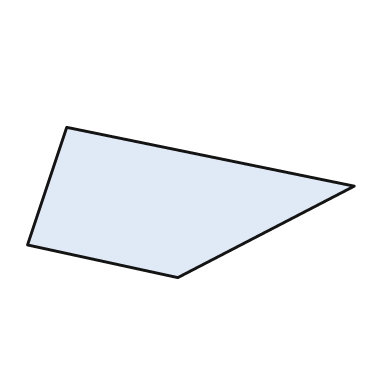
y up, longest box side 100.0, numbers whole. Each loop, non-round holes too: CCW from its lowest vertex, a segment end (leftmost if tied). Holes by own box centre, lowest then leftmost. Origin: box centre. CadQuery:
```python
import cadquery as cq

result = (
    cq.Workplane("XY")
    .moveTo(-4.0, -23.0)
    .lineTo(50.0, 5.0)
    .lineTo(-38.0, 23.0)
    .lineTo(-50.0, -13.0)
    .close()
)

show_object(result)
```